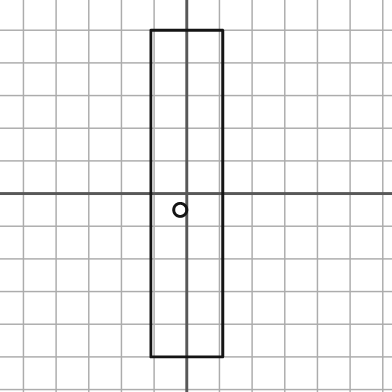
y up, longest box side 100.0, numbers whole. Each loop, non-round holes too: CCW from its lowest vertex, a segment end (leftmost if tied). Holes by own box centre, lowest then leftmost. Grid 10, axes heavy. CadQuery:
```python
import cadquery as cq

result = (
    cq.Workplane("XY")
    .moveTo(-11.0, -50.0)
    .lineTo(11.0, -50.0)
    .lineTo(11.0, 50.0)
    .lineTo(-11.0, 50.0)
    .close()
    .moveTo(-2.0, -5.0)
    .circle(2.0)
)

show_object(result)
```